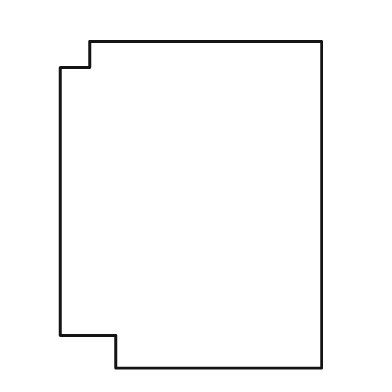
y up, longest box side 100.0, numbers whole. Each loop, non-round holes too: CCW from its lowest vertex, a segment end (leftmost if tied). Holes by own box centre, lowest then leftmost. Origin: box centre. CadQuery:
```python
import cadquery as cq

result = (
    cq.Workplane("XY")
    .moveTo(-23.0, -50.0)
    .lineTo(40.0, -50.0)
    .lineTo(40.0, 50.0)
    .lineTo(-31.0, 50.0)
    .lineTo(-31.0, 42.0)
    .lineTo(-40.0, 42.0)
    .lineTo(-40.0, -40.0)
    .lineTo(-23.0, -40.0)
    .close()
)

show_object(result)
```